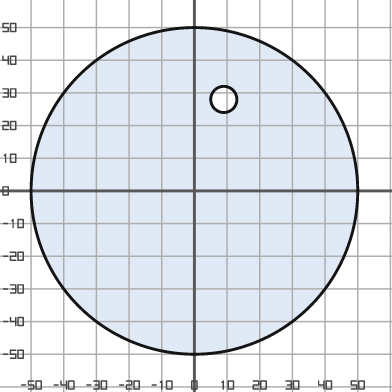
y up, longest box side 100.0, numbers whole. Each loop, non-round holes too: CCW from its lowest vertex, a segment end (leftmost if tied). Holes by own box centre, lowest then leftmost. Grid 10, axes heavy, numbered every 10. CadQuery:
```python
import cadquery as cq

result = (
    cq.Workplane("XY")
    .moveTo(0.0, 0.0)
    .circle(50.0)
    .moveTo(9.0, 28.0)
    .circle(4.0)
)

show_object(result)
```